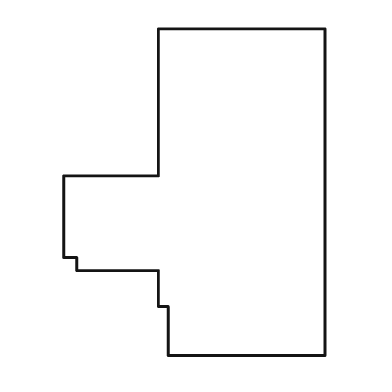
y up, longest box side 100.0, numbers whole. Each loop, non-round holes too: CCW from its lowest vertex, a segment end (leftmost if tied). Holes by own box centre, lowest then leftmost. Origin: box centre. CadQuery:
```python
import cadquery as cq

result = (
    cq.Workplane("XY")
    .moveTo(-8.0, -50.0)
    .lineTo(40.0, -50.0)
    .lineTo(40.0, 50.0)
    .lineTo(-11.0, 50.0)
    .lineTo(-11.0, 5.0)
    .lineTo(-40.0, 5.0)
    .lineTo(-40.0, -20.0)
    .lineTo(-36.0, -20.0)
    .lineTo(-36.0, -24.0)
    .lineTo(-11.0, -24.0)
    .lineTo(-11.0, -35.0)
    .lineTo(-8.0, -35.0)
    .close()
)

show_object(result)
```